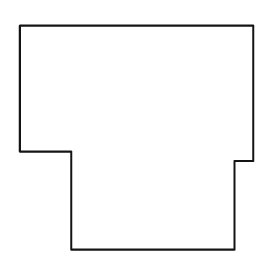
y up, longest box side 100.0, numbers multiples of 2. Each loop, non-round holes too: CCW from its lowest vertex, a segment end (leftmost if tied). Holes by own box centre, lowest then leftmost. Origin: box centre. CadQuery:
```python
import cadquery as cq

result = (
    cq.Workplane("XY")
    .moveTo(-28.0, -48.0)
    .lineTo(42.0, -48.0)
    .lineTo(42.0, -10.0)
    .lineTo(50.0, -10.0)
    .lineTo(50.0, 48.0)
    .lineTo(-50.0, 48.0)
    .lineTo(-50.0, -6.0)
    .lineTo(-28.0, -6.0)
    .close()
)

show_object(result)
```